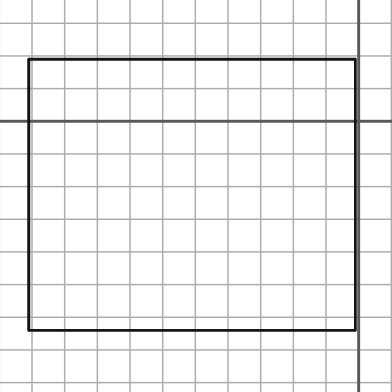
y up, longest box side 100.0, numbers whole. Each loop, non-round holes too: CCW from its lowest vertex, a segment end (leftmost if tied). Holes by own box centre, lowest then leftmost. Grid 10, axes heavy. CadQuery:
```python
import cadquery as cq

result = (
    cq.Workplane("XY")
    .moveTo(-101.0, -64.0)
    .lineTo(-1.0, -64.0)
    .lineTo(-1.0, 19.0)
    .lineTo(-101.0, 19.0)
    .close()
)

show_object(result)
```